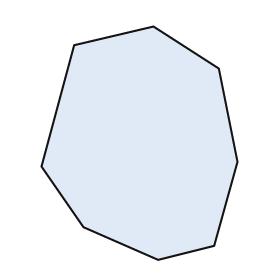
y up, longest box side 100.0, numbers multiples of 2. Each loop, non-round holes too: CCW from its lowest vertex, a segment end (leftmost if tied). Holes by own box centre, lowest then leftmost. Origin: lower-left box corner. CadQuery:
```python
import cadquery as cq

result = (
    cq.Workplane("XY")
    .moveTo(50.0, 0.0)
    .lineTo(74.0, 6.0)
    .lineTo(84.0, 42.0)
    .lineTo(76.0, 82.0)
    .lineTo(48.0, 100.0)
    .lineTo(14.0, 92.0)
    .lineTo(0.0, 40.0)
    .lineTo(18.0, 14.0)
    .close()
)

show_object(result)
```